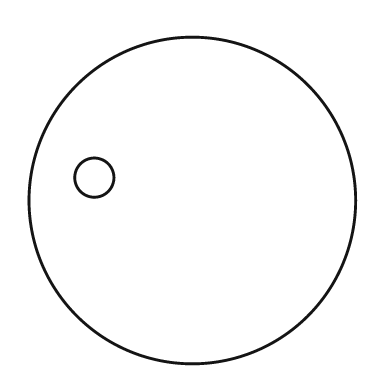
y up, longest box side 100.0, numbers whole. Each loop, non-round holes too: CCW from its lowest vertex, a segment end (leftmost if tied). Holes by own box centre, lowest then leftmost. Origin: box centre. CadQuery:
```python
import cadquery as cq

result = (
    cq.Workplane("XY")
    .moveTo(0.0, 0.0)
    .circle(50.0)
    .moveTo(-30.0, 7.0)
    .circle(6.0)
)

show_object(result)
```